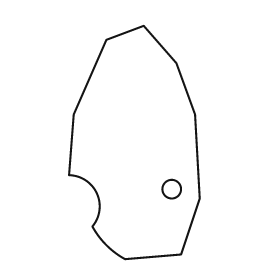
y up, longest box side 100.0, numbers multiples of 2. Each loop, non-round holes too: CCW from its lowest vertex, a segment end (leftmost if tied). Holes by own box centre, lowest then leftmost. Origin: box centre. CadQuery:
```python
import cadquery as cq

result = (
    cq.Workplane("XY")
    .moveTo(-4.0, -50.0)
    .lineTo(20.0, -48.0)
    .lineTo(28.0, -24.0)
    .lineTo(26.0, 12.0)
    .lineTo(18.0, 34.0)
    .lineTo(4.0, 50.0)
    .lineTo(-12.0, 44.0)
    .lineTo(-26.0, 12.0)
    .lineTo(-28.0, -14.0)
    .threePointArc((-16.0, -22.0), (-18.0, -36.0))
    .threePointArc((-12.0, -44.0), (-4.0, -50.0))
    .close()
    .moveTo(16.0, -20.0)
    .circle(4.0)
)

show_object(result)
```